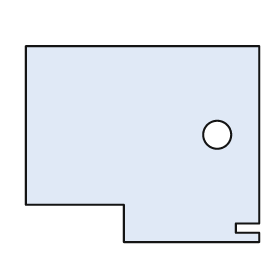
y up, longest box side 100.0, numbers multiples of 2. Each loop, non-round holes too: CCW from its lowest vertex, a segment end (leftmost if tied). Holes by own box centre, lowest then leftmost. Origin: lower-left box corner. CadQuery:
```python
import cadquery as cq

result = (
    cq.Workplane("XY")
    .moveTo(42.0, 0.0)
    .lineTo(100.0, 0.0)
    .lineTo(100.0, 4.0)
    .lineTo(90.0, 4.0)
    .lineTo(90.0, 8.0)
    .lineTo(100.0, 8.0)
    .lineTo(100.0, 84.0)
    .lineTo(0.0, 84.0)
    .lineTo(0.0, 16.0)
    .lineTo(42.0, 16.0)
    .close()
    .moveTo(82.0, 46.0)
    .circle(6.0)
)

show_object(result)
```